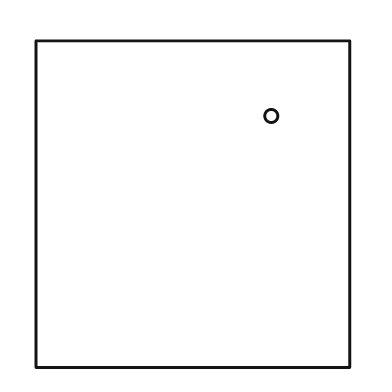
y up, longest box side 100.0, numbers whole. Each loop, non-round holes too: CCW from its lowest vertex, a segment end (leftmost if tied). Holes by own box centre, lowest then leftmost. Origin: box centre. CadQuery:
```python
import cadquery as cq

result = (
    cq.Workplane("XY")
    .moveTo(-48.0, -50.0)
    .lineTo(48.0, -50.0)
    .lineTo(48.0, 50.0)
    .lineTo(-48.0, 50.0)
    .close()
    .moveTo(24.0, 27.0)
    .circle(2.0)
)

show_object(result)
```